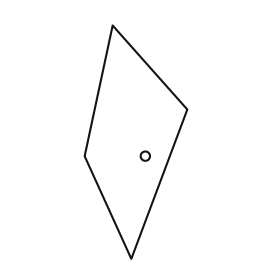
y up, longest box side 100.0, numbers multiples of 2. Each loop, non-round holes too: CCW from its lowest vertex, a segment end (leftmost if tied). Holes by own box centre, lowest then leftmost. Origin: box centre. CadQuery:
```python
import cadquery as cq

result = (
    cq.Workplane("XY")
    .moveTo(-2.0, -50.0)
    .lineTo(22.0, 14.0)
    .lineTo(-10.0, 50.0)
    .lineTo(-22.0, -6.0)
    .close()
    .moveTo(4.0, -6.0)
    .circle(2.0)
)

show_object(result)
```